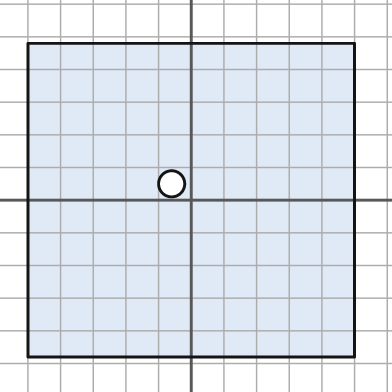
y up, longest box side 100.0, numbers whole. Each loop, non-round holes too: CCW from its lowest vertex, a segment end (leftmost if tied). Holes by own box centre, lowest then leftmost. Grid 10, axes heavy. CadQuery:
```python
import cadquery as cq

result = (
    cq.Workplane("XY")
    .moveTo(-50.0, -48.0)
    .lineTo(50.0, -48.0)
    .lineTo(50.0, 48.0)
    .lineTo(-50.0, 48.0)
    .close()
    .moveTo(-6.0, 5.0)
    .circle(4.0)
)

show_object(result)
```